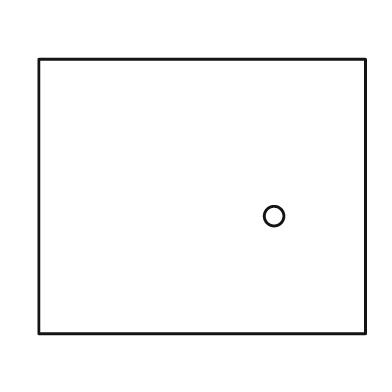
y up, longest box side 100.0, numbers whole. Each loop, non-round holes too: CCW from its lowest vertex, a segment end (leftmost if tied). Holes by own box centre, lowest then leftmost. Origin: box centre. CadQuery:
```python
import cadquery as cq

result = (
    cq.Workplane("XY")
    .moveTo(-50.0, -42.0)
    .lineTo(50.0, -42.0)
    .lineTo(50.0, 42.0)
    .lineTo(-50.0, 42.0)
    .close()
    .moveTo(22.0, -6.0)
    .circle(3.0)
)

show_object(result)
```